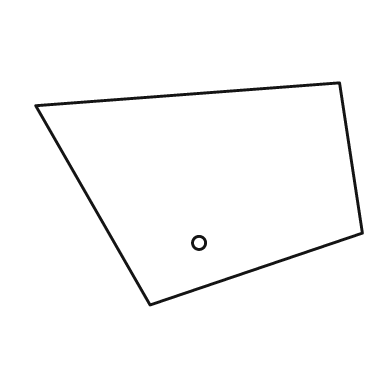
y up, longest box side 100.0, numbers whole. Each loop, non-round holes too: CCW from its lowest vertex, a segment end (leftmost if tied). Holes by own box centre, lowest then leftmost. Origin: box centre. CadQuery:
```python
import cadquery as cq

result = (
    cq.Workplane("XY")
    .moveTo(-15.0, -34.0)
    .lineTo(50.0, -12.0)
    .lineTo(43.0, 34.0)
    .lineTo(-50.0, 27.0)
    .close()
    .moveTo(0.0, -15.0)
    .circle(2.0)
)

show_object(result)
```